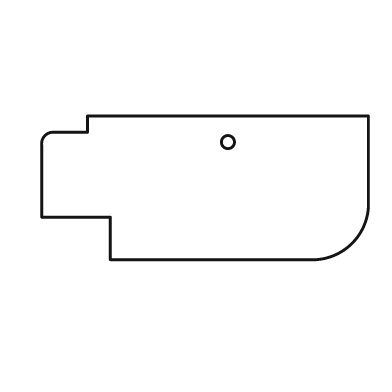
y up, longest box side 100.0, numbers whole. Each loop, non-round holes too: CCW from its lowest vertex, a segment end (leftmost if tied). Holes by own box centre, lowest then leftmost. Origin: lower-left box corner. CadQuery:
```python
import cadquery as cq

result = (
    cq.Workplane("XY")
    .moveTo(21.0, 0.0)
    .lineTo(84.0, 0.0)
    .threePointArc((95.0, 5.0), (100.0, 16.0))
    .lineTo(100.0, 44.0)
    .lineTo(14.0, 44.0)
    .lineTo(14.0, 39.0)
    .lineTo(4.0, 39.0)
    .threePointArc((1.0, 38.0), (0.0, 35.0))
    .lineTo(0.0, 13.0)
    .lineTo(21.0, 13.0)
    .close()
    .moveTo(57.0, 36.0)
    .circle(2.0)
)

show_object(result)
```